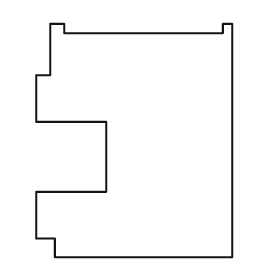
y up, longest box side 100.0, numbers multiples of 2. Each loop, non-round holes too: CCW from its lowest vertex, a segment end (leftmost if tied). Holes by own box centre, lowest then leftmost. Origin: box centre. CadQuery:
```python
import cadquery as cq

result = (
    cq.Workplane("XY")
    .moveTo(-34.0, -50.0)
    .lineTo(42.0, -50.0)
    .lineTo(42.0, 50.0)
    .lineTo(38.0, 50.0)
    .lineTo(38.0, 46.0)
    .lineTo(-30.0, 46.0)
    .lineTo(-30.0, 50.0)
    .lineTo(-36.0, 50.0)
    .lineTo(-36.0, 28.0)
    .lineTo(-42.0, 28.0)
    .lineTo(-42.0, 8.0)
    .lineTo(-12.0, 8.0)
    .lineTo(-12.0, -22.0)
    .lineTo(-42.0, -22.0)
    .lineTo(-42.0, -42.0)
    .lineTo(-34.0, -42.0)
    .close()
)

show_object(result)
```